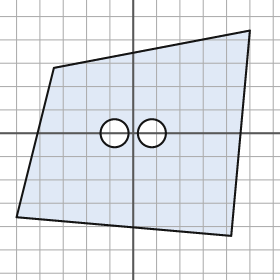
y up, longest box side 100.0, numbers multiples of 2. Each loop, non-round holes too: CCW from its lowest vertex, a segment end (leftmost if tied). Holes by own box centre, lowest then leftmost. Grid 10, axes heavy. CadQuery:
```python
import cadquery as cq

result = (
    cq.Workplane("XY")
    .moveTo(42.0, -44.0)
    .lineTo(50.0, 44.0)
    .lineTo(-34.0, 28.0)
    .lineTo(-50.0, -36.0)
    .close()
    .moveTo(-8.0, 0.0)
    .circle(6.0)
    .moveTo(8.0, 0.0)
    .circle(6.0)
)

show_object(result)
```